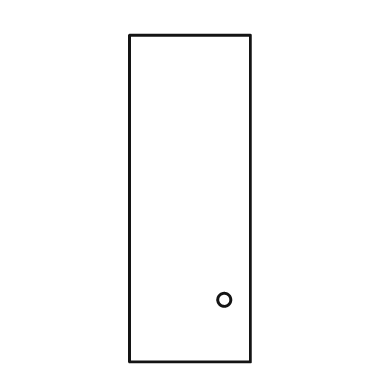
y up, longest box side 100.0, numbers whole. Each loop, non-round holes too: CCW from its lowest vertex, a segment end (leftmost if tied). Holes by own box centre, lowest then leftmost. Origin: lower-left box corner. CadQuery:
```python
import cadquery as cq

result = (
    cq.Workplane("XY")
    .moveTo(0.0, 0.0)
    .lineTo(37.0, 0.0)
    .lineTo(37.0, 100.0)
    .lineTo(0.0, 100.0)
    .close()
    .moveTo(29.0, 19.0)
    .circle(2.0)
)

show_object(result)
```